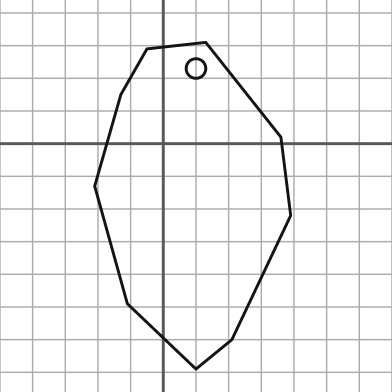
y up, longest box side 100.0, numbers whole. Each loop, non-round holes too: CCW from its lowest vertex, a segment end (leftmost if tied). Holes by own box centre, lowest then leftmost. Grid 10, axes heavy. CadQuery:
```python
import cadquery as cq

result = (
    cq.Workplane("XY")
    .moveTo(10.0, -69.0)
    .lineTo(21.0, -60.0)
    .lineTo(39.0, -22.0)
    .lineTo(36.0, 2.0)
    .lineTo(13.0, 31.0)
    .lineTo(-5.0, 29.0)
    .lineTo(-13.0, 15.0)
    .lineTo(-21.0, -13.0)
    .lineTo(-11.0, -49.0)
    .close()
    .moveTo(10.0, 23.0)
    .circle(3.0)
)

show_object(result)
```